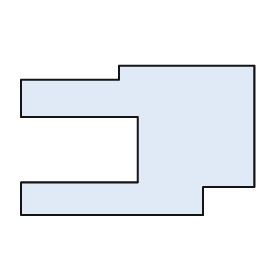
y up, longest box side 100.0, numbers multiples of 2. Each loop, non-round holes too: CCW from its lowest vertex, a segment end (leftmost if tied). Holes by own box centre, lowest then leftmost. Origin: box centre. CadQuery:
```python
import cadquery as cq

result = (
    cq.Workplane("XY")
    .moveTo(-50.0, -32.0)
    .lineTo(28.0, -32.0)
    .lineTo(28.0, -20.0)
    .lineTo(50.0, -20.0)
    .lineTo(50.0, 32.0)
    .lineTo(-8.0, 32.0)
    .lineTo(-8.0, 26.0)
    .lineTo(-50.0, 26.0)
    .lineTo(-50.0, 10.0)
    .lineTo(0.0, 10.0)
    .lineTo(0.0, -18.0)
    .lineTo(-50.0, -18.0)
    .close()
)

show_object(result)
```